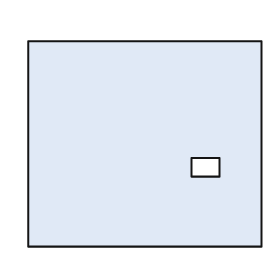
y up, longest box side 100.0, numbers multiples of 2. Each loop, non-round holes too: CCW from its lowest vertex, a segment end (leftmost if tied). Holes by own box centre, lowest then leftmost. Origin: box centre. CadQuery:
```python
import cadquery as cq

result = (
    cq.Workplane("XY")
    .moveTo(-50.0, -44.0)
    .lineTo(50.0, -44.0)
    .lineTo(50.0, 44.0)
    .lineTo(-50.0, 44.0)
    .close()
    .moveTo(20.0, -14.0)
    .lineTo(32.0, -14.0)
    .lineTo(32.0, -6.0)
    .lineTo(20.0, -6.0)
    .close()
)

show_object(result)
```